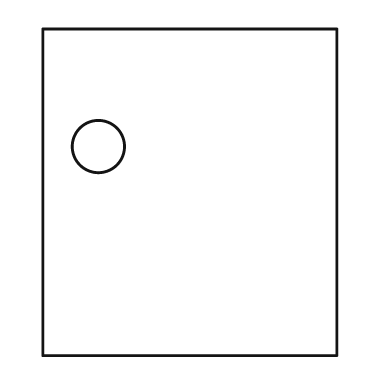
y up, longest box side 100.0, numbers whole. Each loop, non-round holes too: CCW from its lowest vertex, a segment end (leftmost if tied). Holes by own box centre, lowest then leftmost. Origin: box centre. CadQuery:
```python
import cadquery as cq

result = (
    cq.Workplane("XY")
    .moveTo(-45.0, -50.0)
    .lineTo(45.0, -50.0)
    .lineTo(45.0, 50.0)
    .lineTo(-45.0, 50.0)
    .close()
    .moveTo(-28.0, 14.0)
    .circle(8.0)
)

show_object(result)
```